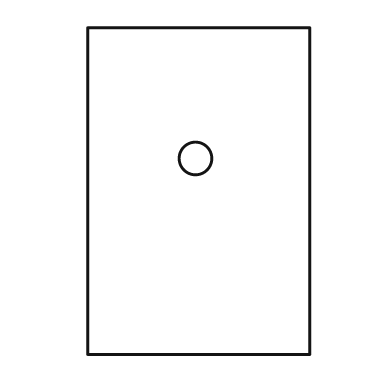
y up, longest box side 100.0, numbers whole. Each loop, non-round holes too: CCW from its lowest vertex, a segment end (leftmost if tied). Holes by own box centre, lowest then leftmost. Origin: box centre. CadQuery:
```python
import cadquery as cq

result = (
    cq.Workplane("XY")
    .moveTo(-34.0, -50.0)
    .lineTo(34.0, -50.0)
    .lineTo(34.0, 50.0)
    .lineTo(-34.0, 50.0)
    .close()
    .moveTo(-1.0, 10.0)
    .circle(5.0)
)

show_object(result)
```